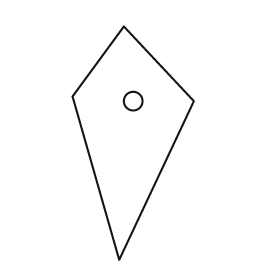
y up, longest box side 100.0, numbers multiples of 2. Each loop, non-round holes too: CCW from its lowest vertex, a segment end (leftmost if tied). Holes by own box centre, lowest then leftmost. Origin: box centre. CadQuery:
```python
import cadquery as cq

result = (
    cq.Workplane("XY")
    .moveTo(-6.0, -50.0)
    .lineTo(26.0, 18.0)
    .lineTo(-4.0, 50.0)
    .lineTo(-26.0, 20.0)
    .close()
    .moveTo(0.0, 18.0)
    .circle(4.0)
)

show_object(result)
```